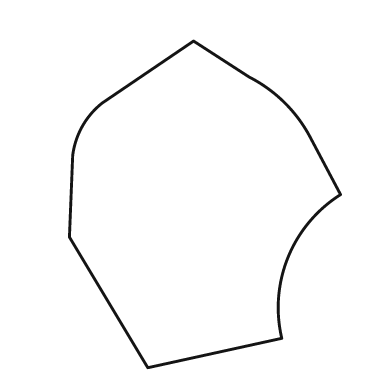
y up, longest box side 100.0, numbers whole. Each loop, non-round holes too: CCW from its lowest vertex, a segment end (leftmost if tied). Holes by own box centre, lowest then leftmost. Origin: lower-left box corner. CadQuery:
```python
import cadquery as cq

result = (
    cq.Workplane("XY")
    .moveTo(24.0, 0.0)
    .lineTo(65.0, 9.0)
    .threePointArc((67.0, 34.0), (83.0, 53.0))
    .lineTo(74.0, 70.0)
    .threePointArc((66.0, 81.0), (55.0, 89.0))
    .lineTo(38.0, 100.0)
    .lineTo(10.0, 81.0)
    .threePointArc((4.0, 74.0), (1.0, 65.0))
    .lineTo(0.0, 40.0)
    .close()
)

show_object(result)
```